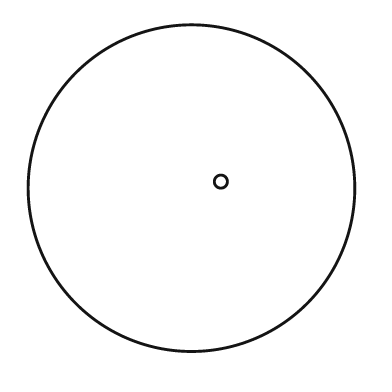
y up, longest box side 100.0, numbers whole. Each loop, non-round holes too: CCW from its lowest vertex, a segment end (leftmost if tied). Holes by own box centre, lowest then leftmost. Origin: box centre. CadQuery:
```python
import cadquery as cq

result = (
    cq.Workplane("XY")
    .moveTo(0.0, 0.0)
    .circle(50.0)
    .moveTo(9.0, 2.0)
    .circle(2.0)
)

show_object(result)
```